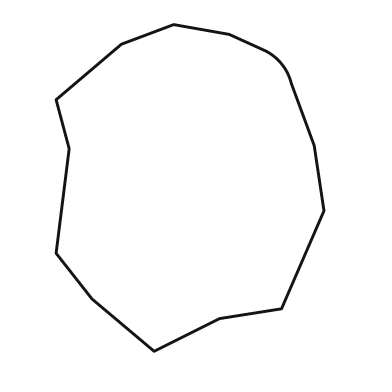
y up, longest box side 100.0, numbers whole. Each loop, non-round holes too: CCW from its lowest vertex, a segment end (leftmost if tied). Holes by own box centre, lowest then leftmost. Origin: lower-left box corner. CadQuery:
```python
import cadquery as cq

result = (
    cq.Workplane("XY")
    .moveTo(30.0, 0.0)
    .lineTo(50.0, 10.0)
    .lineTo(69.0, 13.0)
    .lineTo(82.0, 43.0)
    .lineTo(79.0, 63.0)
    .lineTo(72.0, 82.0)
    .threePointArc((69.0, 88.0), (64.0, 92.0))
    .lineTo(53.0, 97.0)
    .lineTo(36.0, 100.0)
    .lineTo(20.0, 94.0)
    .lineTo(0.0, 77.0)
    .lineTo(4.0, 62.0)
    .lineTo(0.0, 30.0)
    .lineTo(11.0, 16.0)
    .close()
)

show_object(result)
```